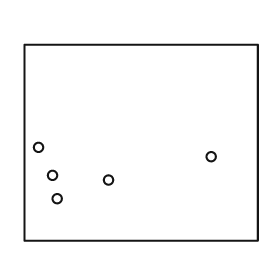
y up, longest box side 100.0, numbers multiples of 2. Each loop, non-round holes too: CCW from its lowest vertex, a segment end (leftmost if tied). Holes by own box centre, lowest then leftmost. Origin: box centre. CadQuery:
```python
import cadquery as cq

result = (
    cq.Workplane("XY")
    .moveTo(-50.0, -42.0)
    .lineTo(50.0, -42.0)
    .lineTo(50.0, 42.0)
    .lineTo(-50.0, 42.0)
    .close()
    .moveTo(-36.0, -24.0)
    .circle(2.0)
    .moveTo(-14.0, -16.0)
    .circle(2.0)
    .moveTo(-38.0, -14.0)
    .circle(2.0)
    .moveTo(30.0, -6.0)
    .circle(2.0)
    .moveTo(-44.0, -2.0)
    .circle(2.0)
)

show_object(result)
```